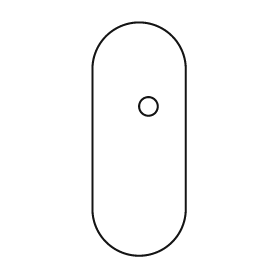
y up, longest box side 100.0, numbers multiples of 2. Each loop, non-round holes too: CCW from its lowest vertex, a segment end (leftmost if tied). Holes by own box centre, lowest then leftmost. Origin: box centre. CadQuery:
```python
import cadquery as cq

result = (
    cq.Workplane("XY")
    .moveTo(-20.0, -30.0)
    .threePointArc((0.0, -50.0), (20.0, -30.0))
    .lineTo(20.0, 30.0)
    .threePointArc((0.0, 50.0), (-20.0, 30.0))
    .close()
    .moveTo(4.0, 14.0)
    .circle(4.0)
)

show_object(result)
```